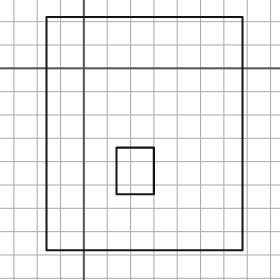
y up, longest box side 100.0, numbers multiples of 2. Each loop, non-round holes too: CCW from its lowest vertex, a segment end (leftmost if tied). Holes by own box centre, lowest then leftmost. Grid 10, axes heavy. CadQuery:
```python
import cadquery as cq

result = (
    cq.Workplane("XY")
    .moveTo(-16.0, -78.0)
    .lineTo(68.0, -78.0)
    .lineTo(68.0, 22.0)
    .lineTo(-16.0, 22.0)
    .close()
    .moveTo(14.0, -54.0)
    .lineTo(30.0, -54.0)
    .lineTo(30.0, -34.0)
    .lineTo(14.0, -34.0)
    .close()
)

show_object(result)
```